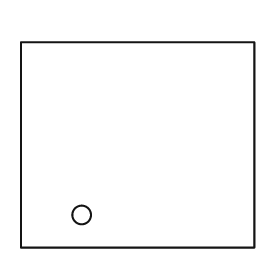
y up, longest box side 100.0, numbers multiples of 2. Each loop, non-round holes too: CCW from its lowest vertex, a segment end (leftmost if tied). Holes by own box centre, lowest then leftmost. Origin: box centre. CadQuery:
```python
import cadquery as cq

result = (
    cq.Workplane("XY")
    .moveTo(-50.0, -44.0)
    .lineTo(50.0, -44.0)
    .lineTo(50.0, 44.0)
    .lineTo(-50.0, 44.0)
    .close()
    .moveTo(-24.0, -30.0)
    .circle(4.0)
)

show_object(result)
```